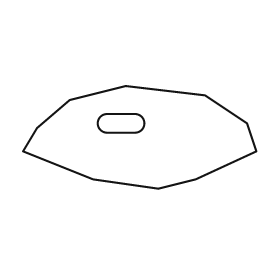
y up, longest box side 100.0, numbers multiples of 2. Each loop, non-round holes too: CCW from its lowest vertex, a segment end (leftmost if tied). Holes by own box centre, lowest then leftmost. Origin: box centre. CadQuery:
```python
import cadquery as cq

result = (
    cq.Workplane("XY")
    .moveTo(8.0, -22.0)
    .lineTo(24.0, -18.0)
    .lineTo(50.0, -6.0)
    .lineTo(46.0, 6.0)
    .lineTo(28.0, 18.0)
    .lineTo(-6.0, 22.0)
    .lineTo(-30.0, 16.0)
    .lineTo(-44.0, 4.0)
    .lineTo(-50.0, -6.0)
    .lineTo(-20.0, -18.0)
    .close()
    .moveTo(-14.0, 2.0)
    .lineTo(-2.0, 2.0)
    .threePointArc((2.0, 6.0), (-2.0, 10.0))
    .lineTo(-14.0, 10.0)
    .threePointArc((-18.0, 6.0), (-14.0, 2.0))
    .close()
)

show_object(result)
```